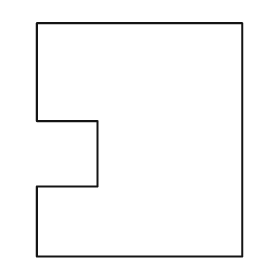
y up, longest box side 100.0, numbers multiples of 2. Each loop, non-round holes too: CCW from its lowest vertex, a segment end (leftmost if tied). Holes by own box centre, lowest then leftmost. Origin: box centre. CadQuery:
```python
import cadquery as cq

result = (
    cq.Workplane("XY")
    .moveTo(-44.0, -50.0)
    .lineTo(44.0, -50.0)
    .lineTo(44.0, 50.0)
    .lineTo(-44.0, 50.0)
    .lineTo(-44.0, 8.0)
    .lineTo(-18.0, 8.0)
    .lineTo(-18.0, -20.0)
    .lineTo(-44.0, -20.0)
    .close()
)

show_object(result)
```